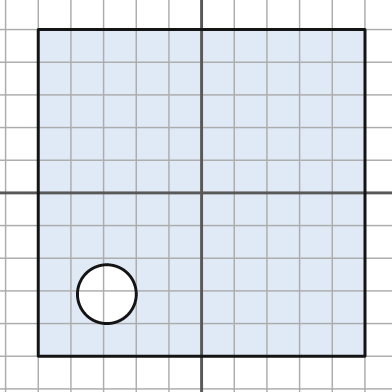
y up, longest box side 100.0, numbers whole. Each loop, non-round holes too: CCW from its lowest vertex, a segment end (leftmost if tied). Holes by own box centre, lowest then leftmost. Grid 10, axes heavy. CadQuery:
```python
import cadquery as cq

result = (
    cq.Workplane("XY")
    .moveTo(-50.0, -50.0)
    .lineTo(50.0, -50.0)
    .lineTo(50.0, 50.0)
    .lineTo(-50.0, 50.0)
    .close()
    .moveTo(-29.0, -31.0)
    .circle(9.0)
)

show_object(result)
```